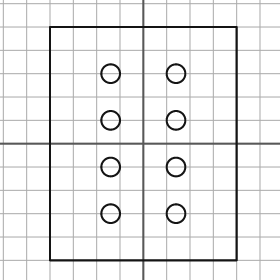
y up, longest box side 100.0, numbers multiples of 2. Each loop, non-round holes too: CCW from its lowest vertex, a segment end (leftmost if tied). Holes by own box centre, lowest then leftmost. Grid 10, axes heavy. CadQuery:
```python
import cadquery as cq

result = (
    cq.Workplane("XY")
    .moveTo(-40.0, -50.0)
    .lineTo(40.0, -50.0)
    .lineTo(40.0, 50.0)
    .lineTo(-40.0, 50.0)
    .close()
    .moveTo(-14.0, -30.0)
    .circle(4.0)
    .moveTo(14.0, -30.0)
    .circle(4.0)
    .moveTo(-14.0, -10.0)
    .circle(4.0)
    .moveTo(14.0, -10.0)
    .circle(4.0)
    .moveTo(-14.0, 10.0)
    .circle(4.0)
    .moveTo(14.0, 10.0)
    .circle(4.0)
    .moveTo(-14.0, 30.0)
    .circle(4.0)
    .moveTo(14.0, 30.0)
    .circle(4.0)
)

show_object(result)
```